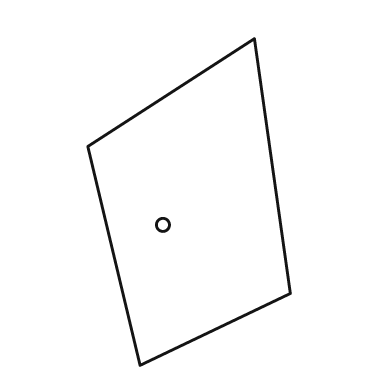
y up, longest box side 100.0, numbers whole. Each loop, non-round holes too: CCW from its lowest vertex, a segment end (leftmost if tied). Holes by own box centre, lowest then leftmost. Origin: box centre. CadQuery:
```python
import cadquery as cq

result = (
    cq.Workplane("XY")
    .moveTo(-15.0, -50.0)
    .lineTo(31.0, -28.0)
    .lineTo(20.0, 50.0)
    .lineTo(-31.0, 17.0)
    .close()
    .moveTo(-8.0, -7.0)
    .circle(2.0)
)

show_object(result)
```